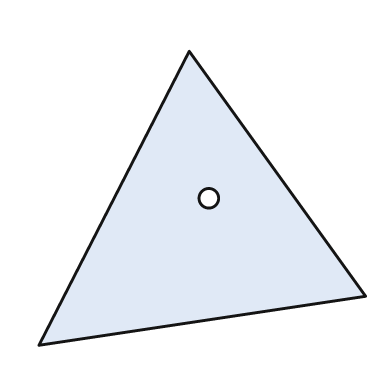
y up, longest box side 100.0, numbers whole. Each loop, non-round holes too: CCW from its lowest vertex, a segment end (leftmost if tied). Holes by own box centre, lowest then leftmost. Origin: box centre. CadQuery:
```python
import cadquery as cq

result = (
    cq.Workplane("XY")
    .moveTo(-50.0, -45.0)
    .lineTo(50.0, -30.0)
    .lineTo(-4.0, 45.0)
    .close()
    .moveTo(2.0, 0.0)
    .circle(3.0)
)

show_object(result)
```